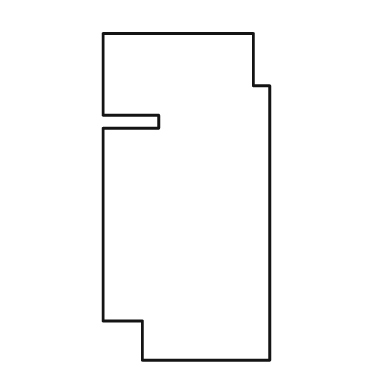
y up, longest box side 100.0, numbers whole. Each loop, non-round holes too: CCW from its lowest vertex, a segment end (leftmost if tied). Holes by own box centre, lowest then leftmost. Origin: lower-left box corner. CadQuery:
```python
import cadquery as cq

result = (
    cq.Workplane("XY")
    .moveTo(12.0, 0.0)
    .lineTo(51.0, 0.0)
    .lineTo(51.0, 84.0)
    .lineTo(46.0, 84.0)
    .lineTo(46.0, 100.0)
    .lineTo(0.0, 100.0)
    .lineTo(0.0, 75.0)
    .lineTo(17.0, 75.0)
    .lineTo(17.0, 71.0)
    .lineTo(0.0, 71.0)
    .lineTo(0.0, 12.0)
    .lineTo(12.0, 12.0)
    .close()
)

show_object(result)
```